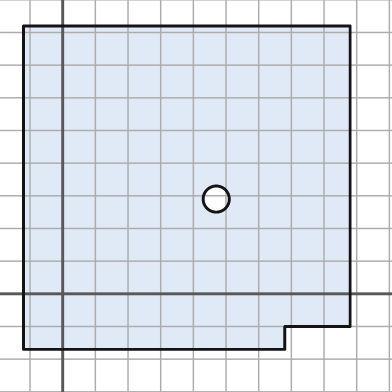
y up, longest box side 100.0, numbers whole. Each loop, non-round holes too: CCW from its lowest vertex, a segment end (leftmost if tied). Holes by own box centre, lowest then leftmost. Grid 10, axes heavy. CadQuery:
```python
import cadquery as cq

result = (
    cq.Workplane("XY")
    .moveTo(-12.0, -17.0)
    .lineTo(68.0, -17.0)
    .lineTo(68.0, -10.0)
    .lineTo(88.0, -10.0)
    .lineTo(88.0, 82.0)
    .lineTo(-12.0, 82.0)
    .close()
    .moveTo(47.0, 29.0)
    .circle(4.0)
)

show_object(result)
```